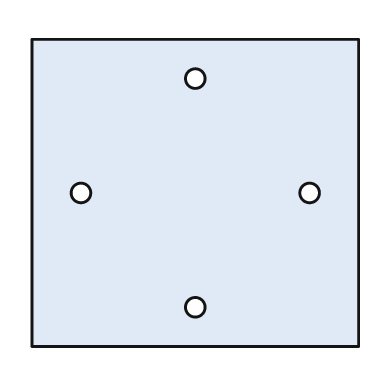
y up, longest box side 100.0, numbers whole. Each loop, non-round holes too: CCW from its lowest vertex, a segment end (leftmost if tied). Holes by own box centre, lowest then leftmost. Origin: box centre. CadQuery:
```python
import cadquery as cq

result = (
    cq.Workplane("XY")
    .moveTo(-50.0, -47.0)
    .lineTo(50.0, -47.0)
    .lineTo(50.0, 47.0)
    .lineTo(-50.0, 47.0)
    .close()
    .moveTo(0.0, -35.0)
    .circle(3.0)
    .moveTo(-35.0, 0.0)
    .circle(3.0)
    .moveTo(35.0, 0.0)
    .circle(3.0)
    .moveTo(0.0, 35.0)
    .circle(3.0)
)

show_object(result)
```